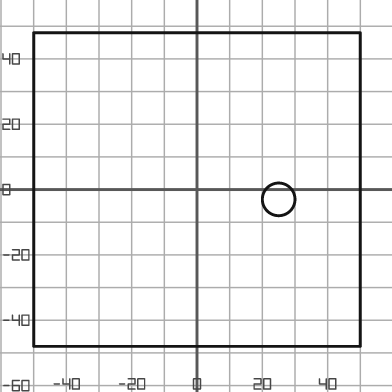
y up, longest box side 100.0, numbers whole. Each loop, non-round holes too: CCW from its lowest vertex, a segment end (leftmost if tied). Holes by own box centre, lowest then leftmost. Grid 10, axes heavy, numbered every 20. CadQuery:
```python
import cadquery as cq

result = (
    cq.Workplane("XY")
    .moveTo(-50.0, -48.0)
    .lineTo(50.0, -48.0)
    .lineTo(50.0, 48.0)
    .lineTo(-50.0, 48.0)
    .close()
    .moveTo(25.0, -3.0)
    .circle(5.0)
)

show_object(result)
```